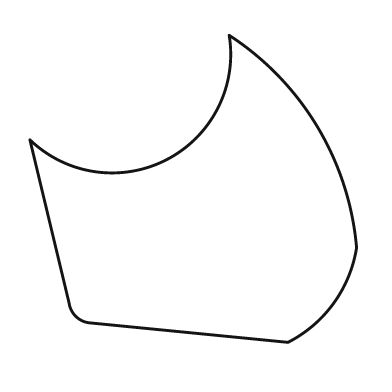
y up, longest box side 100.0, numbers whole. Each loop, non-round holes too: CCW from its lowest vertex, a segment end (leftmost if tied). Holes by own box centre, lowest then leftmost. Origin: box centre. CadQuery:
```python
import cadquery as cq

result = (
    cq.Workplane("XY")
    .moveTo(29.0, -47.0)
    .threePointArc((43.0, -35.0), (50.0, -18.0))
    .threePointArc((38.0, 19.0), (11.0, 47.0))
    .threePointArc((-8.0, 9.0), (-50.0, 15.0))
    .lineTo(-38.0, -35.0)
    .threePointArc((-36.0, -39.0), (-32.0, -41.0))
    .close()
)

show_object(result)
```